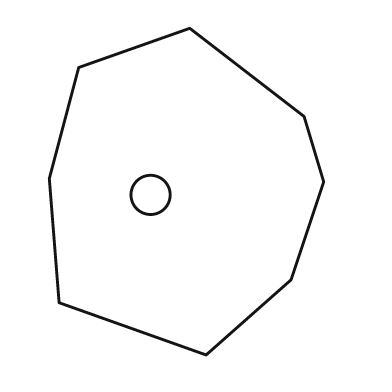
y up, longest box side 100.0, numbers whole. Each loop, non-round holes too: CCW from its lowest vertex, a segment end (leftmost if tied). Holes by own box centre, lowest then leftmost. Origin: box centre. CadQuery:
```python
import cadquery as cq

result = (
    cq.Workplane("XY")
    .moveTo(6.0, -50.0)
    .lineTo(32.0, -27.0)
    .lineTo(42.0, 3.0)
    .lineTo(36.0, 23.0)
    .lineTo(1.0, 50.0)
    .lineTo(-33.0, 38.0)
    .lineTo(-42.0, 4.0)
    .lineTo(-39.0, -34.0)
    .close()
    .moveTo(-11.0, -1.0)
    .circle(6.0)
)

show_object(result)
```